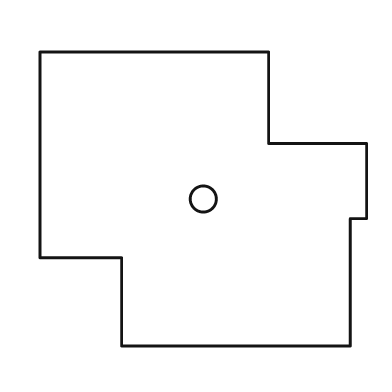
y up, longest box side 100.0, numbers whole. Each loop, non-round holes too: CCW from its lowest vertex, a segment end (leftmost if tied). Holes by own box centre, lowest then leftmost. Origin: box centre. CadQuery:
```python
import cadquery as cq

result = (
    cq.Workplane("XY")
    .moveTo(-25.0, -45.0)
    .lineTo(45.0, -45.0)
    .lineTo(45.0, -6.0)
    .lineTo(50.0, -6.0)
    .lineTo(50.0, 17.0)
    .lineTo(20.0, 17.0)
    .lineTo(20.0, 45.0)
    .lineTo(-50.0, 45.0)
    .lineTo(-50.0, -18.0)
    .lineTo(-25.0, -18.0)
    .close()
    .moveTo(0.0, 0.0)
    .circle(4.0)
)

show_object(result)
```